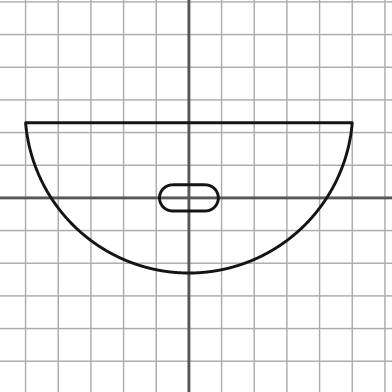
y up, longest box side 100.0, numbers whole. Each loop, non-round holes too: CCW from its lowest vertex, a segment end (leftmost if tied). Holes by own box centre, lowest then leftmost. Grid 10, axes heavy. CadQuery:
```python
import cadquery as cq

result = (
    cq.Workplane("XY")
    .moveTo(-50.0, 23.0)
    .threePointArc((0.0, -23.0), (50.0, 23.0))
    .close()
    .moveTo(-5.0, -4.0)
    .lineTo(5.0, -4.0)
    .threePointArc((9.0, 0.0), (5.0, 4.0))
    .lineTo(-5.0, 4.0)
    .threePointArc((-9.0, 0.0), (-5.0, -4.0))
    .close()
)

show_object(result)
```